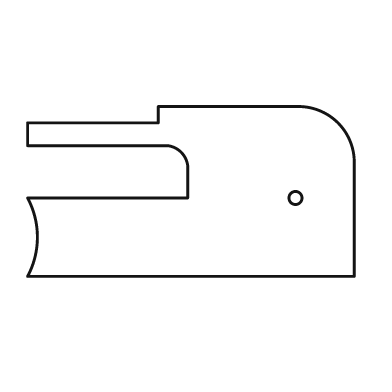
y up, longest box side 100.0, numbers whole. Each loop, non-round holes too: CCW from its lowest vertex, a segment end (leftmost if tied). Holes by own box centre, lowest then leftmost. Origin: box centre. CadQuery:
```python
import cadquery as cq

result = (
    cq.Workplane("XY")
    .moveTo(-50.0, -26.0)
    .lineTo(50.0, -26.0)
    .lineTo(50.0, 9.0)
    .threePointArc((45.0, 21.0), (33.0, 26.0))
    .lineTo(-10.0, 26.0)
    .lineTo(-10.0, 21.0)
    .lineTo(-50.0, 21.0)
    .lineTo(-50.0, 14.0)
    .lineTo(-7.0, 14.0)
    .threePointArc((-3.0, 12.0), (-1.0, 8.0))
    .lineTo(-1.0, -2.0)
    .lineTo(-50.0, -2.0)
    .threePointArc((-47.0, -14.0), (-50.0, -26.0))
    .close()
    .moveTo(32.0, -2.0)
    .circle(2.0)
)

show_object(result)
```